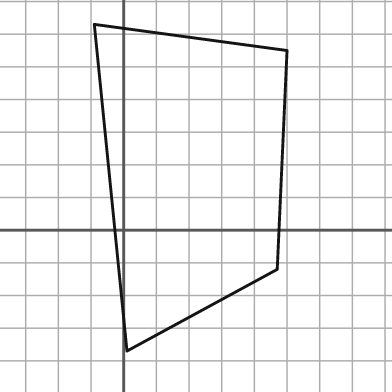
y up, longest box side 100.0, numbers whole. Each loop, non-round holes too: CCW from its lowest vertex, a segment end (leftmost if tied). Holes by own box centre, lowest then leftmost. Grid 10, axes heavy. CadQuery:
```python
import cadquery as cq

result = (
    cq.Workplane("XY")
    .moveTo(1.0, -37.0)
    .lineTo(47.0, -12.0)
    .lineTo(50.0, 55.0)
    .lineTo(-9.0, 63.0)
    .close()
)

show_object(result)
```